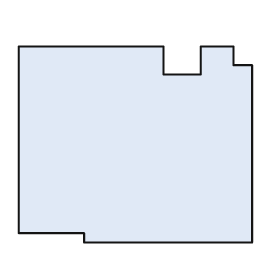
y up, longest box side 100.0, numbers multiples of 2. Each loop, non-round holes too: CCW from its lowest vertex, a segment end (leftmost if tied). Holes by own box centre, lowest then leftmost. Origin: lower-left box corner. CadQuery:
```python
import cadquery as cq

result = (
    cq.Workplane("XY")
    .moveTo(28.0, 0.0)
    .lineTo(100.0, 0.0)
    .lineTo(100.0, 76.0)
    .lineTo(92.0, 76.0)
    .lineTo(92.0, 84.0)
    .lineTo(78.0, 84.0)
    .lineTo(78.0, 72.0)
    .lineTo(62.0, 72.0)
    .lineTo(62.0, 84.0)
    .lineTo(0.0, 84.0)
    .lineTo(0.0, 4.0)
    .lineTo(28.0, 4.0)
    .close()
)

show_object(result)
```